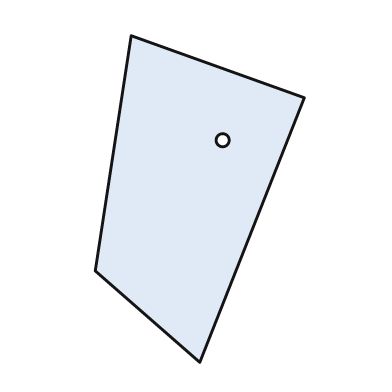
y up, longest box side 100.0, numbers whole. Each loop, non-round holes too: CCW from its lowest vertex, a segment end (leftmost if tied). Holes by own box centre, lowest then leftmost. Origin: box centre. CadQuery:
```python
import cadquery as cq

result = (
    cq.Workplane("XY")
    .moveTo(0.0, -50.0)
    .lineTo(32.0, 31.0)
    .lineTo(-21.0, 50.0)
    .lineTo(-32.0, -22.0)
    .close()
    .moveTo(7.0, 18.0)
    .circle(2.0)
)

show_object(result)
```